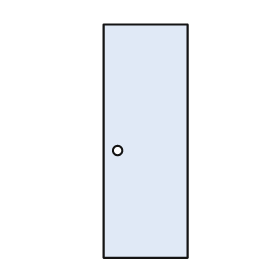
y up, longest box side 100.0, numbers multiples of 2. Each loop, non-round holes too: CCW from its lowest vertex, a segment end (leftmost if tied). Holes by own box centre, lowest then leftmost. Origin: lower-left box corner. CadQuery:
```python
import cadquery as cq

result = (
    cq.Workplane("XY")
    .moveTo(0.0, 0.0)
    .lineTo(36.0, 0.0)
    .lineTo(36.0, 100.0)
    .lineTo(0.0, 100.0)
    .close()
    .moveTo(6.0, 46.0)
    .circle(2.0)
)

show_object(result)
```